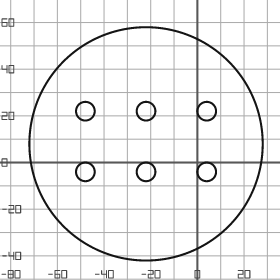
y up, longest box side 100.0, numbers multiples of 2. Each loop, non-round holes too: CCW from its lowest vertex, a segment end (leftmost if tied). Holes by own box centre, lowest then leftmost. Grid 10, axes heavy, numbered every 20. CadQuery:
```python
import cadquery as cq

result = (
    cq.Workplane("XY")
    .moveTo(-22.0, 8.0)
    .circle(50.0)
    .moveTo(-48.0, -4.0)
    .circle(4.0)
    .moveTo(-22.0, -4.0)
    .circle(4.0)
    .moveTo(4.0, -4.0)
    .circle(4.0)
    .moveTo(-48.0, 22.0)
    .circle(4.0)
    .moveTo(-22.0, 22.0)
    .circle(4.0)
    .moveTo(4.0, 22.0)
    .circle(4.0)
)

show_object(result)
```